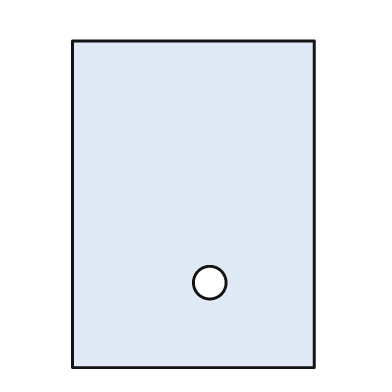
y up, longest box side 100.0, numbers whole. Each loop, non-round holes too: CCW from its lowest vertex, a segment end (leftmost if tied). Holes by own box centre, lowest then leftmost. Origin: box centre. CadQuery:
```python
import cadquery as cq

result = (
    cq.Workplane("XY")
    .moveTo(-37.0, -50.0)
    .lineTo(37.0, -50.0)
    .lineTo(37.0, 50.0)
    .lineTo(-37.0, 50.0)
    .close()
    .moveTo(5.0, -24.0)
    .circle(5.0)
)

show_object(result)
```